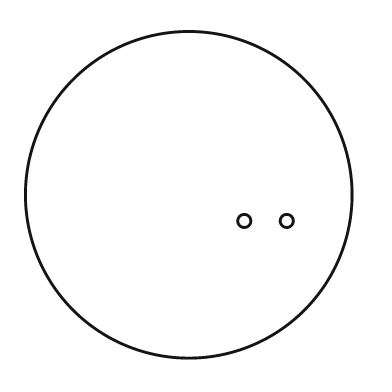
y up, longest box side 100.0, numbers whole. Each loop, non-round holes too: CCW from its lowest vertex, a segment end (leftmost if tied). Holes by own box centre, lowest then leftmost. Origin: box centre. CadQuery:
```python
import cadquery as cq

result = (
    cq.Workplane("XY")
    .moveTo(0.0, 0.0)
    .circle(50.0)
    .moveTo(17.0, -8.0)
    .circle(2.0)
    .moveTo(30.0, -8.0)
    .circle(2.0)
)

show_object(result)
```